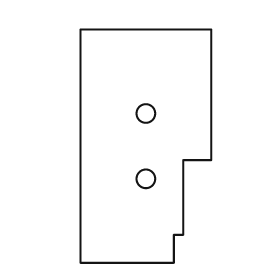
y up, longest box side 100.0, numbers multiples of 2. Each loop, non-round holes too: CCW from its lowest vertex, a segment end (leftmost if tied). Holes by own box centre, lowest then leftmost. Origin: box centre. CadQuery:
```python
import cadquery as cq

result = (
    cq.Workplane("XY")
    .moveTo(-28.0, -50.0)
    .lineTo(12.0, -50.0)
    .lineTo(12.0, -38.0)
    .lineTo(16.0, -38.0)
    .lineTo(16.0, -6.0)
    .lineTo(28.0, -6.0)
    .lineTo(28.0, 50.0)
    .lineTo(-28.0, 50.0)
    .close()
    .moveTo(0.0, -14.0)
    .circle(4.0)
    .moveTo(0.0, 14.0)
    .circle(4.0)
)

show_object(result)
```